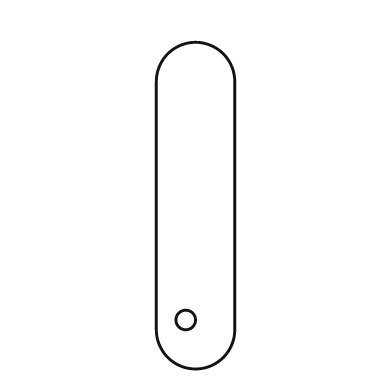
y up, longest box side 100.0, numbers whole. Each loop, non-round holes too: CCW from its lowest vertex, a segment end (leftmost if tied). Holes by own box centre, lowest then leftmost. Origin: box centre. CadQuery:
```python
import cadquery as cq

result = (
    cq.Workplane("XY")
    .moveTo(-12.0, -38.0)
    .threePointArc((0.0, -50.0), (12.0, -38.0))
    .lineTo(12.0, 38.0)
    .threePointArc((0.0, 50.0), (-12.0, 38.0))
    .close()
    .moveTo(-3.0, -35.0)
    .circle(3.0)
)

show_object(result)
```